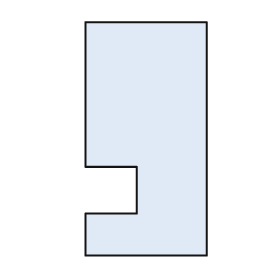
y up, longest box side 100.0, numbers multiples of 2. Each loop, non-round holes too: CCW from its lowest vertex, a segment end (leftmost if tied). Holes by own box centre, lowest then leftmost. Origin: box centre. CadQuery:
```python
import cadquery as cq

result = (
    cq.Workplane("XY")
    .moveTo(-26.0, -50.0)
    .lineTo(26.0, -50.0)
    .lineTo(26.0, 50.0)
    .lineTo(-26.0, 50.0)
    .lineTo(-26.0, -12.0)
    .lineTo(-4.0, -12.0)
    .lineTo(-4.0, -32.0)
    .lineTo(-26.0, -32.0)
    .close()
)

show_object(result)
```